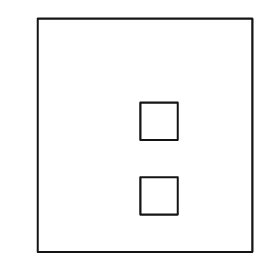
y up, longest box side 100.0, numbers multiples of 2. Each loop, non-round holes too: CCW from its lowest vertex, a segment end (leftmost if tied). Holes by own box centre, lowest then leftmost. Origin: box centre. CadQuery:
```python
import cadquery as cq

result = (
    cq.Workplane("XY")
    .moveTo(-46.0, -50.0)
    .lineTo(46.0, -50.0)
    .lineTo(46.0, 50.0)
    .lineTo(-46.0, 50.0)
    .close()
    .moveTo(-2.0, -34.0)
    .lineTo(14.0, -34.0)
    .lineTo(14.0, -18.0)
    .lineTo(-2.0, -18.0)
    .close()
    .moveTo(-2.0, -2.0)
    .lineTo(14.0, -2.0)
    .lineTo(14.0, 14.0)
    .lineTo(-2.0, 14.0)
    .close()
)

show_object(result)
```